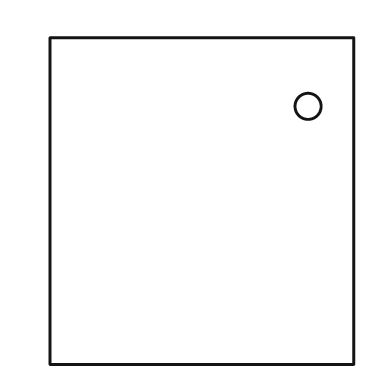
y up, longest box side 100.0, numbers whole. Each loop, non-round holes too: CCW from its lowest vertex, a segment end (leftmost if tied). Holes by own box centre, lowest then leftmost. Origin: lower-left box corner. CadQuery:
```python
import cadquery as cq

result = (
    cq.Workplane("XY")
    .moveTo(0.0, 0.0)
    .lineTo(93.0, 0.0)
    .lineTo(93.0, 100.0)
    .lineTo(0.0, 100.0)
    .close()
    .moveTo(79.0, 79.0)
    .circle(4.0)
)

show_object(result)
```